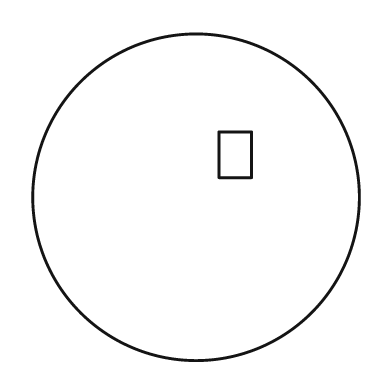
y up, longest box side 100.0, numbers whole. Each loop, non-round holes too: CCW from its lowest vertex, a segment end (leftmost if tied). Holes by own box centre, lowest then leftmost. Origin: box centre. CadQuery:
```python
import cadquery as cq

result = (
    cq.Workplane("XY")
    .moveTo(0.0, 0.0)
    .circle(50.0)
    .moveTo(7.0, 6.0)
    .lineTo(17.0, 6.0)
    .lineTo(17.0, 20.0)
    .lineTo(7.0, 20.0)
    .close()
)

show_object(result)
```